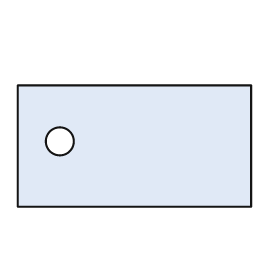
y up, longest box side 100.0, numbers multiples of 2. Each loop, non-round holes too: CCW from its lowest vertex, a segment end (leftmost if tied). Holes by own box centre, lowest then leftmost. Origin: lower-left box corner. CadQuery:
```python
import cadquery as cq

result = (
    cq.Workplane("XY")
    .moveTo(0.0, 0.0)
    .lineTo(100.0, 0.0)
    .lineTo(100.0, 52.0)
    .lineTo(0.0, 52.0)
    .close()
    .moveTo(18.0, 28.0)
    .circle(6.0)
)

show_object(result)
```